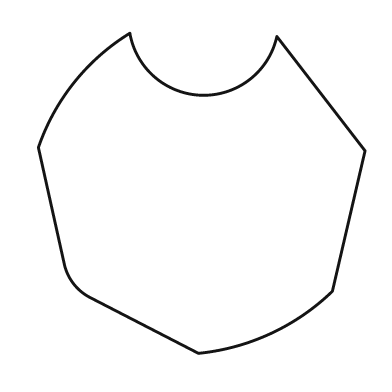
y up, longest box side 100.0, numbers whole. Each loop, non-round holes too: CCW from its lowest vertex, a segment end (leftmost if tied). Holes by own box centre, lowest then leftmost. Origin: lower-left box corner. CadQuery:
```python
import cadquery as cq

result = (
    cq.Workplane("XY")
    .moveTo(49.0, 0.0)
    .threePointArc((71.0, 6.0), (90.0, 19.0))
    .lineTo(100.0, 62.0)
    .lineTo(73.0, 97.0)
    .threePointArc((50.0, 79.0), (28.0, 98.0))
    .threePointArc((11.0, 83.0), (0.0, 63.0))
    .lineTo(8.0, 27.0)
    .threePointArc((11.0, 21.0), (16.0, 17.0))
    .close()
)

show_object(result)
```